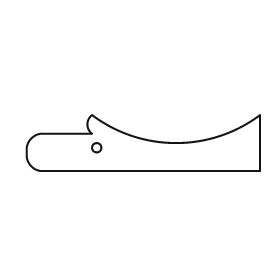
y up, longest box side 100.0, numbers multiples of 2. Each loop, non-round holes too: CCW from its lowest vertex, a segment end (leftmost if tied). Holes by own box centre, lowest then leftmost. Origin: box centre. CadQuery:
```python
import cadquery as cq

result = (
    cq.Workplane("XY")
    .moveTo(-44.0, -12.0)
    .lineTo(50.0, -12.0)
    .lineTo(50.0, 12.0)
    .threePointArc((14.0, 0.0), (-22.0, 12.0))
    .threePointArc((-24.0, 8.0), (-22.0, 4.0))
    .lineTo(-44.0, 4.0)
    .threePointArc((-48.0, 2.0), (-50.0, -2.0))
    .lineTo(-50.0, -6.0)
    .threePointArc((-48.0, -10.0), (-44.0, -12.0))
    .close()
    .moveTo(-20.0, -2.0)
    .circle(2.0)
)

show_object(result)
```